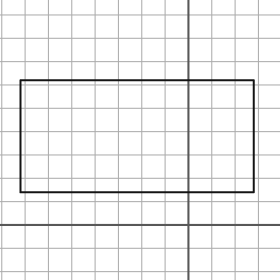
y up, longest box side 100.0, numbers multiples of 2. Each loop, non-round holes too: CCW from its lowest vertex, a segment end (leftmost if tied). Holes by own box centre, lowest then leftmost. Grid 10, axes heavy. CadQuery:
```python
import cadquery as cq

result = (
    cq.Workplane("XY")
    .moveTo(-72.0, 14.0)
    .lineTo(28.0, 14.0)
    .lineTo(28.0, 62.0)
    .lineTo(-72.0, 62.0)
    .close()
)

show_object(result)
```